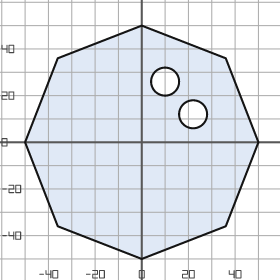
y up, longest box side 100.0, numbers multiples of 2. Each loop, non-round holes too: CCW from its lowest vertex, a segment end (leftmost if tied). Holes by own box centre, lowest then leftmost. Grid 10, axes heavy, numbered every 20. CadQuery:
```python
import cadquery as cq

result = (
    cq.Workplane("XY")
    .moveTo(0.0, -50.0)
    .lineTo(36.0, -36.0)
    .lineTo(50.0, 0.0)
    .lineTo(36.0, 36.0)
    .lineTo(0.0, 50.0)
    .lineTo(-36.0, 36.0)
    .lineTo(-50.0, 0.0)
    .lineTo(-36.0, -36.0)
    .close()
    .moveTo(22.0, 12.0)
    .circle(6.0)
    .moveTo(10.0, 26.0)
    .circle(6.0)
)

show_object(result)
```